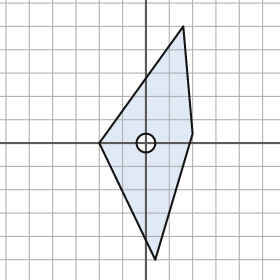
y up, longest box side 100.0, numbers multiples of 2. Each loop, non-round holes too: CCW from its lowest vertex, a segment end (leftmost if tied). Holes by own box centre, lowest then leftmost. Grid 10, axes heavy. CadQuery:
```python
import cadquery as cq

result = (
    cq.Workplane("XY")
    .moveTo(4.0, -50.0)
    .lineTo(20.0, 4.0)
    .lineTo(16.0, 50.0)
    .lineTo(-20.0, 0.0)
    .close()
    .moveTo(0.0, 0.0)
    .circle(4.0)
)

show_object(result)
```